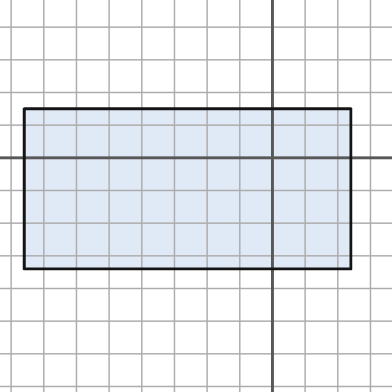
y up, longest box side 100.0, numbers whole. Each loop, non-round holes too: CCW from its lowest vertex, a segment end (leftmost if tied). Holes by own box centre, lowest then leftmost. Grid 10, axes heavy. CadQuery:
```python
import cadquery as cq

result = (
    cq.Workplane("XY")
    .moveTo(-76.0, -34.0)
    .lineTo(24.0, -34.0)
    .lineTo(24.0, 15.0)
    .lineTo(-76.0, 15.0)
    .close()
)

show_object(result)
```